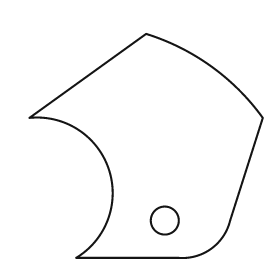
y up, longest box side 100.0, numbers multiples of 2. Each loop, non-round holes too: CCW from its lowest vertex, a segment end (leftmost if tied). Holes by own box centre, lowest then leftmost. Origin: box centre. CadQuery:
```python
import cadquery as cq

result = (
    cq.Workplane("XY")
    .moveTo(-30.0, -48.0)
    .lineTo(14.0, -48.0)
    .threePointArc((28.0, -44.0), (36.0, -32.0))
    .lineTo(50.0, 12.0)
    .threePointArc((28.0, 34.0), (0.0, 48.0))
    .lineTo(-50.0, 12.0)
    .threePointArc((-16.0, -10.0), (-30.0, -48.0))
    .close()
    .moveTo(8.0, -32.0)
    .circle(6.0)
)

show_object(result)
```